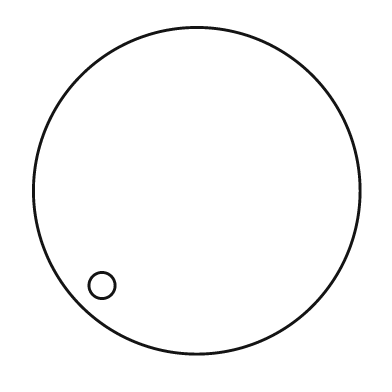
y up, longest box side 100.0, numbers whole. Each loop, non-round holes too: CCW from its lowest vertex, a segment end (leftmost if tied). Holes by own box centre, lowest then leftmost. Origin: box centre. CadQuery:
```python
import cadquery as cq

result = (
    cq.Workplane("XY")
    .moveTo(0.0, 0.0)
    .circle(50.0)
    .moveTo(-29.0, -29.0)
    .circle(4.0)
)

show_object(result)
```